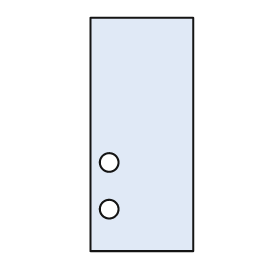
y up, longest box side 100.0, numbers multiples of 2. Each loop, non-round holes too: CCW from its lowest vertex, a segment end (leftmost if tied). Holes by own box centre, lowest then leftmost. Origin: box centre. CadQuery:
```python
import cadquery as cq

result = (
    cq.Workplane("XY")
    .moveTo(-22.0, -50.0)
    .lineTo(22.0, -50.0)
    .lineTo(22.0, 50.0)
    .lineTo(-22.0, 50.0)
    .close()
    .moveTo(-14.0, -32.0)
    .circle(4.0)
    .moveTo(-14.0, -12.0)
    .circle(4.0)
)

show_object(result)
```